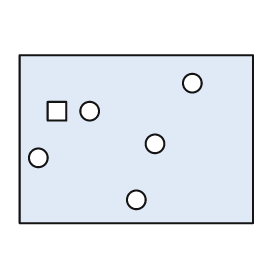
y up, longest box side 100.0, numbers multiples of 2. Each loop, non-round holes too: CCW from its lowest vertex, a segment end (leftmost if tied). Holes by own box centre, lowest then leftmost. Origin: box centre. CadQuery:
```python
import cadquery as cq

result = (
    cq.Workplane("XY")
    .moveTo(-50.0, -36.0)
    .lineTo(50.0, -36.0)
    .lineTo(50.0, 36.0)
    .lineTo(-50.0, 36.0)
    .close()
    .moveTo(0.0, -26.0)
    .circle(4.0)
    .moveTo(-42.0, -8.0)
    .circle(4.0)
    .moveTo(8.0, -2.0)
    .circle(4.0)
    .moveTo(-38.0, 8.0)
    .lineTo(-30.0, 8.0)
    .lineTo(-30.0, 16.0)
    .lineTo(-38.0, 16.0)
    .close()
    .moveTo(-20.0, 12.0)
    .circle(4.0)
    .moveTo(24.0, 24.0)
    .circle(4.0)
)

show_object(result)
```